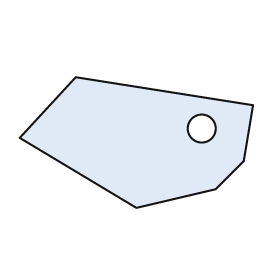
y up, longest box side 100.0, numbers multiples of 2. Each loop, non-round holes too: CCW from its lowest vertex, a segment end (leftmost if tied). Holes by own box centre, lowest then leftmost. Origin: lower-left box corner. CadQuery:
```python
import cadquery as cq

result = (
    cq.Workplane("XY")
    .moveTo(50.0, 0.0)
    .lineTo(84.0, 8.0)
    .lineTo(96.0, 20.0)
    .lineTo(100.0, 44.0)
    .lineTo(24.0, 56.0)
    .lineTo(0.0, 30.0)
    .close()
    .moveTo(78.0, 34.0)
    .circle(6.0)
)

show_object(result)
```